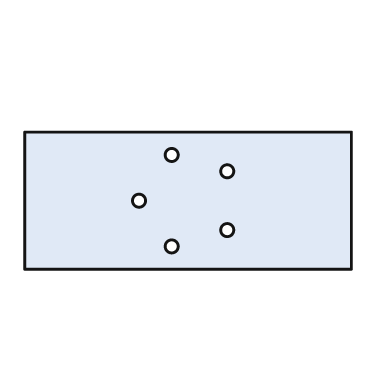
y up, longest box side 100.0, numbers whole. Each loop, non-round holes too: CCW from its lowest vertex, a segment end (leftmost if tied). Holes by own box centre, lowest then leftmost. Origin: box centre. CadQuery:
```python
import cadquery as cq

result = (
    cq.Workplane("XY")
    .moveTo(-50.0, -21.0)
    .lineTo(50.0, -21.0)
    .lineTo(50.0, 21.0)
    .lineTo(-50.0, 21.0)
    .close()
    .moveTo(-5.0, -14.0)
    .circle(2.0)
    .moveTo(12.0, -9.0)
    .circle(2.0)
    .moveTo(-15.0, 0.0)
    .circle(2.0)
    .moveTo(12.0, 9.0)
    .circle(2.0)
    .moveTo(-5.0, 14.0)
    .circle(2.0)
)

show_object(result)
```